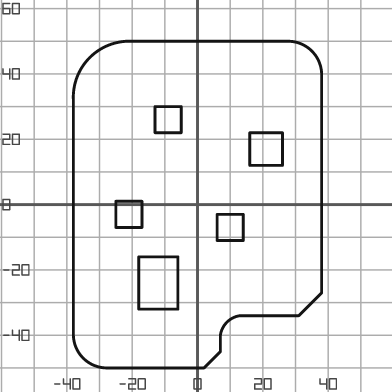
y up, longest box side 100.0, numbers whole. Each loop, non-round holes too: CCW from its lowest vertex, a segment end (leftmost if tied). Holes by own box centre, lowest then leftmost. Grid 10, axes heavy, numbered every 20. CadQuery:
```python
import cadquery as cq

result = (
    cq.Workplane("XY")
    .moveTo(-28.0, -50.0)
    .lineTo(2.0, -50.0)
    .lineTo(7.0, -45.0)
    .lineTo(7.0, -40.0)
    .threePointArc((9.0, -36.0), (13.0, -34.0))
    .lineTo(31.0, -34.0)
    .lineTo(38.0, -27.0)
    .lineTo(38.0, 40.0)
    .threePointArc((35.0, 47.0), (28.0, 50.0))
    .lineTo(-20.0, 50.0)
    .threePointArc((-33.0, 45.0), (-38.0, 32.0))
    .lineTo(-38.0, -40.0)
    .threePointArc((-35.0, -47.0), (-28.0, -50.0))
    .close()
    .moveTo(-18.0, -32.0)
    .lineTo(-6.0, -32.0)
    .lineTo(-6.0, -16.0)
    .lineTo(-18.0, -16.0)
    .close()
    .moveTo(6.0, -11.0)
    .lineTo(14.0, -11.0)
    .lineTo(14.0, -3.0)
    .lineTo(6.0, -3.0)
    .close()
    .moveTo(-25.0, -7.0)
    .lineTo(-17.0, -7.0)
    .lineTo(-17.0, 1.0)
    .lineTo(-25.0, 1.0)
    .close()
    .moveTo(16.0, 12.0)
    .lineTo(26.0, 12.0)
    .lineTo(26.0, 22.0)
    .lineTo(16.0, 22.0)
    .close()
    .moveTo(-13.0, 22.0)
    .lineTo(-5.0, 22.0)
    .lineTo(-5.0, 30.0)
    .lineTo(-13.0, 30.0)
    .close()
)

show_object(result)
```